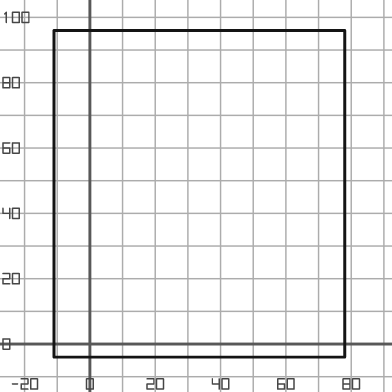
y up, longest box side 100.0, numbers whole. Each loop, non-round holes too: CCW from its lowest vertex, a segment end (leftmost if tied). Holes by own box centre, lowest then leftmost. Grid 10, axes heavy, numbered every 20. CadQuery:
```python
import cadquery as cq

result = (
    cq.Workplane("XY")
    .moveTo(-11.0, -4.0)
    .lineTo(78.0, -4.0)
    .lineTo(78.0, 96.0)
    .lineTo(-11.0, 96.0)
    .close()
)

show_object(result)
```